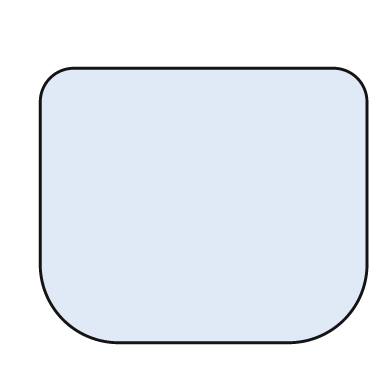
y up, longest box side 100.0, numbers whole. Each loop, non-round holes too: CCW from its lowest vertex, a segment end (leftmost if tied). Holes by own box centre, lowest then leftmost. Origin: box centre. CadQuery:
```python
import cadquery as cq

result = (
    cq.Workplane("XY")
    .moveTo(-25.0, -42.0)
    .lineTo(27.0, -42.0)
    .threePointArc((43.0, -35.0), (50.0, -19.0))
    .lineTo(50.0, 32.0)
    .threePointArc((47.0, 39.0), (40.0, 42.0))
    .lineTo(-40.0, 42.0)
    .threePointArc((-47.0, 39.0), (-50.0, 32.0))
    .lineTo(-50.0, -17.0)
    .threePointArc((-43.0, -35.0), (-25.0, -42.0))
    .close()
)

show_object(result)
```